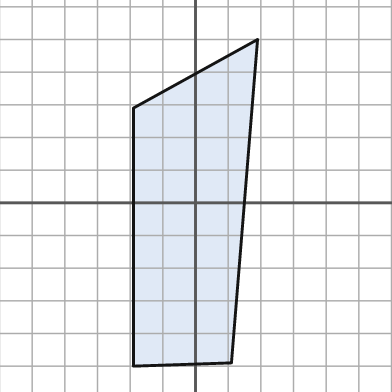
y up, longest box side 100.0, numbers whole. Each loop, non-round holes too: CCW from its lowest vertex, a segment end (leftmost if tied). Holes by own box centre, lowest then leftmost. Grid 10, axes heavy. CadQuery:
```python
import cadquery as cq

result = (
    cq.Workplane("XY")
    .moveTo(-19.0, -50.0)
    .lineTo(11.0, -49.0)
    .lineTo(19.0, 50.0)
    .lineTo(-19.0, 29.0)
    .close()
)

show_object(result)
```